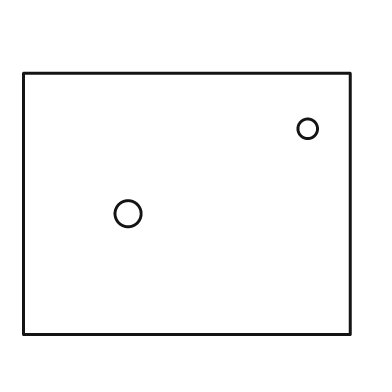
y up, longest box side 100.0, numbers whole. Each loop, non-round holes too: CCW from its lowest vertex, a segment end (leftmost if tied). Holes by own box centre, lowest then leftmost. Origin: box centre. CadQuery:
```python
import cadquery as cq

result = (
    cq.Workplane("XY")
    .moveTo(-50.0, -40.0)
    .lineTo(50.0, -40.0)
    .lineTo(50.0, 40.0)
    .lineTo(-50.0, 40.0)
    .close()
    .moveTo(-18.0, -3.0)
    .circle(4.0)
    .moveTo(37.0, 23.0)
    .circle(3.0)
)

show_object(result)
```